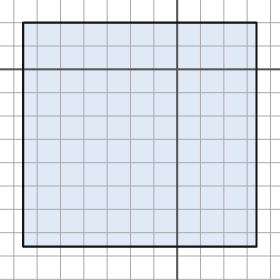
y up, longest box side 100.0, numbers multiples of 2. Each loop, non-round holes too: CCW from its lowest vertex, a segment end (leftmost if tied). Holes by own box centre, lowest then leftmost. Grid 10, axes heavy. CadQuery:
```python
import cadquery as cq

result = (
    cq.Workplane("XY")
    .moveTo(-66.0, -76.0)
    .lineTo(34.0, -76.0)
    .lineTo(34.0, 20.0)
    .lineTo(-66.0, 20.0)
    .close()
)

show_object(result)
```